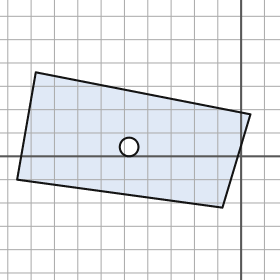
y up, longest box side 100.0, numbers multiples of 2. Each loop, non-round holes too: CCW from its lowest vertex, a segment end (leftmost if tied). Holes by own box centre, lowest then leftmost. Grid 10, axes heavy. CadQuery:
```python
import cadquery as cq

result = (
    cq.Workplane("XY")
    .moveTo(-8.0, -22.0)
    .lineTo(4.0, 18.0)
    .lineTo(-88.0, 36.0)
    .lineTo(-96.0, -10.0)
    .close()
    .moveTo(-48.0, 4.0)
    .circle(4.0)
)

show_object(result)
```